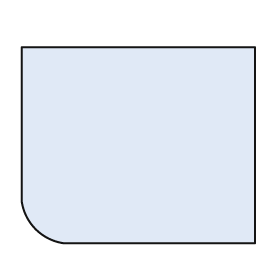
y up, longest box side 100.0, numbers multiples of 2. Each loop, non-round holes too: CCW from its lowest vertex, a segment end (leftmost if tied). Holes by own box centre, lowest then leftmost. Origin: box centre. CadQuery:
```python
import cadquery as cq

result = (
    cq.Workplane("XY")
    .moveTo(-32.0, -42.0)
    .lineTo(50.0, -42.0)
    .lineTo(50.0, 42.0)
    .lineTo(-50.0, 42.0)
    .lineTo(-50.0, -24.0)
    .threePointArc((-44.0, -36.0), (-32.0, -42.0))
    .close()
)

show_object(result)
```